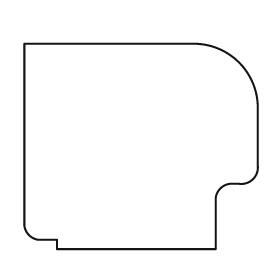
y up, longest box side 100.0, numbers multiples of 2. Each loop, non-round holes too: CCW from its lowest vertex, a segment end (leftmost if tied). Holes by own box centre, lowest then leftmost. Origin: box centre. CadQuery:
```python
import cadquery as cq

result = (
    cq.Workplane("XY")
    .moveTo(-36.0, -44.0)
    .lineTo(32.0, -44.0)
    .lineTo(32.0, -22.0)
    .threePointArc((34.0, -18.0), (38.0, -16.0))
    .lineTo(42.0, -16.0)
    .threePointArc((48.0, -14.0), (50.0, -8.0))
    .lineTo(50.0, 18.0)
    .threePointArc((42.0, 36.0), (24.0, 44.0))
    .lineTo(-50.0, 44.0)
    .lineTo(-50.0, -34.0)
    .threePointArc((-48.0, -38.0), (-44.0, -40.0))
    .lineTo(-36.0, -40.0)
    .close()
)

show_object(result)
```